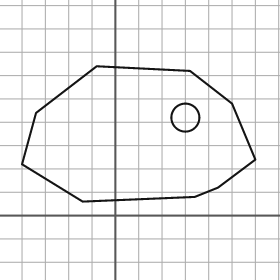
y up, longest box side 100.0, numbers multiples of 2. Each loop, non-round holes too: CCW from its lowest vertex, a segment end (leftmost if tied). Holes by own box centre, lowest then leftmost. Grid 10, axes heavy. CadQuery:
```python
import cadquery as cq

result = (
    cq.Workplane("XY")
    .moveTo(-14.0, 6.0)
    .lineTo(34.0, 8.0)
    .lineTo(44.0, 12.0)
    .lineTo(60.0, 24.0)
    .lineTo(50.0, 48.0)
    .lineTo(32.0, 62.0)
    .lineTo(-8.0, 64.0)
    .lineTo(-34.0, 44.0)
    .lineTo(-40.0, 22.0)
    .close()
    .moveTo(30.0, 42.0)
    .circle(6.0)
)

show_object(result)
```